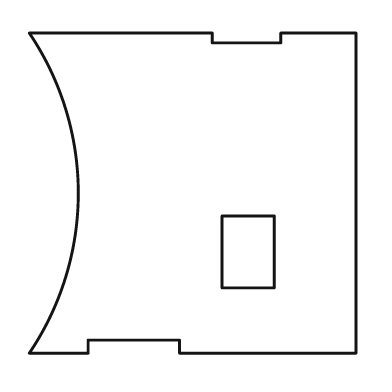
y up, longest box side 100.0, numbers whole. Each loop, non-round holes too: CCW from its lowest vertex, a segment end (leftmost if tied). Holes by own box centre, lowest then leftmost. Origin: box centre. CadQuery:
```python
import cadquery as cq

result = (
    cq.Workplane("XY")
    .moveTo(-50.0, -49.0)
    .lineTo(-32.0, -49.0)
    .lineTo(-32.0, -45.0)
    .lineTo(-4.0, -45.0)
    .lineTo(-4.0, -49.0)
    .lineTo(50.0, -49.0)
    .lineTo(50.0, 49.0)
    .lineTo(27.0, 49.0)
    .lineTo(27.0, 46.0)
    .lineTo(6.0, 46.0)
    .lineTo(6.0, 49.0)
    .lineTo(-50.0, 49.0)
    .threePointArc((-35.0, 0.0), (-50.0, -49.0))
    .close()
    .moveTo(9.0, -29.0)
    .lineTo(25.0, -29.0)
    .lineTo(25.0, -7.0)
    .lineTo(9.0, -7.0)
    .close()
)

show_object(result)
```